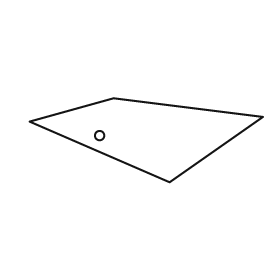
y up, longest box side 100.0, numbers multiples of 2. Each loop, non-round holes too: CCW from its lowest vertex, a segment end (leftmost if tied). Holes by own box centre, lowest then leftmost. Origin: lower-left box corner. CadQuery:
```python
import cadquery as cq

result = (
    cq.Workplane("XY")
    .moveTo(60.0, 0.0)
    .lineTo(100.0, 28.0)
    .lineTo(36.0, 36.0)
    .lineTo(0.0, 26.0)
    .close()
    .moveTo(30.0, 20.0)
    .circle(2.0)
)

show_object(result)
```